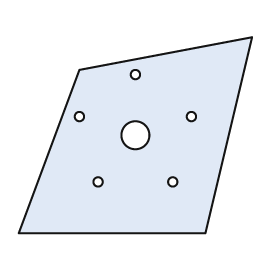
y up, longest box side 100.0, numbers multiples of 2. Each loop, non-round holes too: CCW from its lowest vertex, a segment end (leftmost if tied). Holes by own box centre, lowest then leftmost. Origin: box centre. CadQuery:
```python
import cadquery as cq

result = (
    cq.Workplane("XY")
    .moveTo(-50.0, -42.0)
    .lineTo(30.0, -42.0)
    .lineTo(50.0, 42.0)
    .lineTo(-24.0, 28.0)
    .close()
    .moveTo(-16.0, -20.0)
    .circle(2.0)
    .moveTo(16.0, -20.0)
    .circle(2.0)
    .moveTo(0.0, 0.0)
    .circle(6.0)
    .moveTo(-24.0, 8.0)
    .circle(2.0)
    .moveTo(24.0, 8.0)
    .circle(2.0)
    .moveTo(0.0, 26.0)
    .circle(2.0)
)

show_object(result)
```